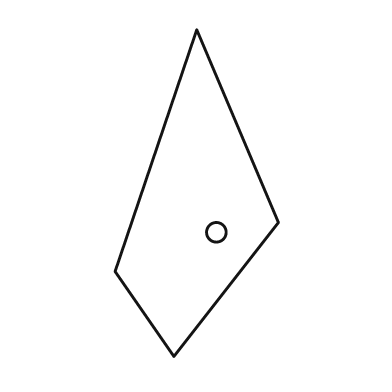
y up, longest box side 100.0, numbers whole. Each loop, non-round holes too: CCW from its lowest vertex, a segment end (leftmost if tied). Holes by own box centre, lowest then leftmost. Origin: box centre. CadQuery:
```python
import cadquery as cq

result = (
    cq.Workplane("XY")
    .moveTo(-7.0, -50.0)
    .lineTo(25.0, -9.0)
    .lineTo(0.0, 50.0)
    .lineTo(-25.0, -24.0)
    .close()
    .moveTo(6.0, -12.0)
    .circle(3.0)
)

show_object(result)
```